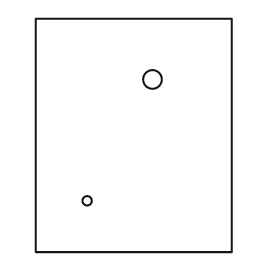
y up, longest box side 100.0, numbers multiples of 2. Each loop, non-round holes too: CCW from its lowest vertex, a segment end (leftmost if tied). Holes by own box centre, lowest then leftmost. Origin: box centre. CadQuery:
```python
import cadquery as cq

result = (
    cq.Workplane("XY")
    .moveTo(-42.0, -50.0)
    .lineTo(42.0, -50.0)
    .lineTo(42.0, 50.0)
    .lineTo(-42.0, 50.0)
    .close()
    .moveTo(-20.0, -28.0)
    .circle(2.0)
    .moveTo(8.0, 24.0)
    .circle(4.0)
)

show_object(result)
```